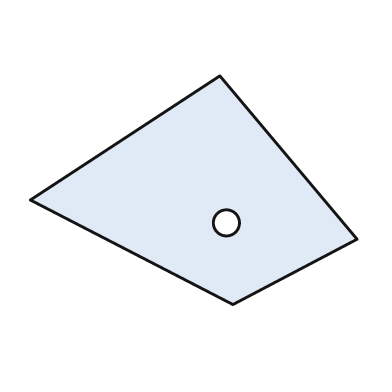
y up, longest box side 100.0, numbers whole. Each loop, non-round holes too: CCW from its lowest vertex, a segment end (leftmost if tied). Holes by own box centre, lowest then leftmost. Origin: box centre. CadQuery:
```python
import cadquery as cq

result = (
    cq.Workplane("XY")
    .moveTo(12.0, -35.0)
    .lineTo(50.0, -15.0)
    .lineTo(8.0, 35.0)
    .lineTo(-50.0, -3.0)
    .close()
    .moveTo(10.0, -10.0)
    .circle(4.0)
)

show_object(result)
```